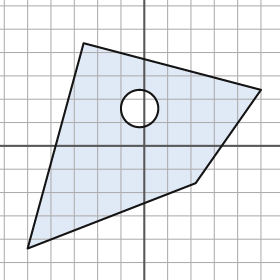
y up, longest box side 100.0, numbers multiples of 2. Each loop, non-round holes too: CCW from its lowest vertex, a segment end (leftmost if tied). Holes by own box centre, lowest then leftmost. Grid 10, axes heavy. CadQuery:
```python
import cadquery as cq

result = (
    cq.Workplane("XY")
    .moveTo(-50.0, -44.0)
    .lineTo(22.0, -16.0)
    .lineTo(50.0, 24.0)
    .lineTo(-26.0, 44.0)
    .close()
    .moveTo(-2.0, 16.0)
    .circle(8.0)
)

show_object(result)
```